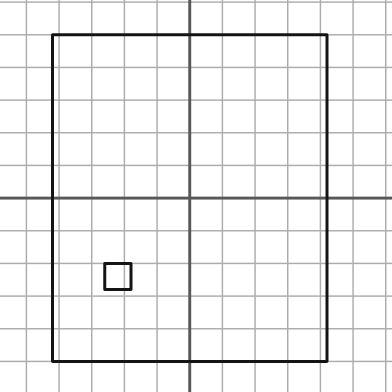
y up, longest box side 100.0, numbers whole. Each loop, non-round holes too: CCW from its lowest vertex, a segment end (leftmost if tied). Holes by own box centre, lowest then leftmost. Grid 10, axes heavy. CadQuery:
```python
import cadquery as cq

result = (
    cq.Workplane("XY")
    .moveTo(-42.0, -50.0)
    .lineTo(42.0, -50.0)
    .lineTo(42.0, 50.0)
    .lineTo(-42.0, 50.0)
    .close()
    .moveTo(-26.0, -28.0)
    .lineTo(-18.0, -28.0)
    .lineTo(-18.0, -20.0)
    .lineTo(-26.0, -20.0)
    .close()
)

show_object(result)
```